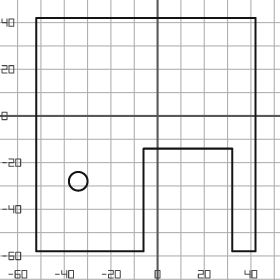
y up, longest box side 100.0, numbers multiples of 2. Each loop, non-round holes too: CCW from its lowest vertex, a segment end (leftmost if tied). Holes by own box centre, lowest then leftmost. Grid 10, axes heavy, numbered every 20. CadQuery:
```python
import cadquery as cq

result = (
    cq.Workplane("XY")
    .moveTo(-52.0, -58.0)
    .lineTo(-6.0, -58.0)
    .lineTo(-6.0, -14.0)
    .lineTo(32.0, -14.0)
    .lineTo(32.0, -58.0)
    .lineTo(42.0, -58.0)
    .lineTo(42.0, 42.0)
    .lineTo(-52.0, 42.0)
    .close()
    .moveTo(-34.0, -28.0)
    .circle(4.0)
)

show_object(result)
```